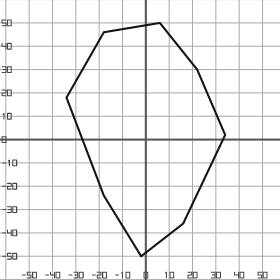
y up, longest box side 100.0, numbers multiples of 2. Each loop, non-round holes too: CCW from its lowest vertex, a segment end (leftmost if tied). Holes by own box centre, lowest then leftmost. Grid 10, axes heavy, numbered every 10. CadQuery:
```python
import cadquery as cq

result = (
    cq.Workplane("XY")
    .moveTo(-2.0, -50.0)
    .lineTo(16.0, -36.0)
    .lineTo(34.0, 2.0)
    .lineTo(22.0, 30.0)
    .lineTo(6.0, 50.0)
    .lineTo(-18.0, 46.0)
    .lineTo(-34.0, 18.0)
    .lineTo(-18.0, -24.0)
    .close()
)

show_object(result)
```